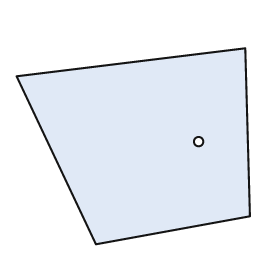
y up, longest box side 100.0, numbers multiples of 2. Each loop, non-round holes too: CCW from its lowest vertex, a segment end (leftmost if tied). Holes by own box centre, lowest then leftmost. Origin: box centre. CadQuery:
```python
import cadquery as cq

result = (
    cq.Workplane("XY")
    .moveTo(-16.0, -42.0)
    .lineTo(50.0, -30.0)
    .lineTo(48.0, 42.0)
    .lineTo(-50.0, 30.0)
    .close()
    .moveTo(28.0, 2.0)
    .circle(2.0)
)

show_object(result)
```